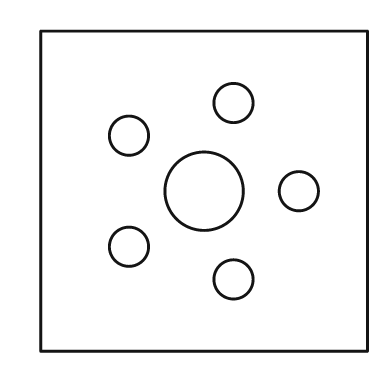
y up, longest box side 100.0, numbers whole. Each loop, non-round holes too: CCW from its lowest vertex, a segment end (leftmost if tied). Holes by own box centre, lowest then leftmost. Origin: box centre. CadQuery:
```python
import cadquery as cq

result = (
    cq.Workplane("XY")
    .moveTo(-50.0, -49.0)
    .lineTo(50.0, -49.0)
    .lineTo(50.0, 49.0)
    .lineTo(-50.0, 49.0)
    .close()
    .moveTo(9.0, -27.0)
    .circle(6.0)
    .moveTo(-23.0, -17.0)
    .circle(6.0)
    .moveTo(0.0, 0.0)
    .circle(12.0)
    .moveTo(29.0, 0.0)
    .circle(6.0)
    .moveTo(-23.0, 17.0)
    .circle(6.0)
    .moveTo(9.0, 27.0)
    .circle(6.0)
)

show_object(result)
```